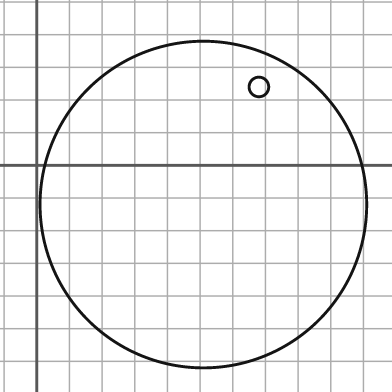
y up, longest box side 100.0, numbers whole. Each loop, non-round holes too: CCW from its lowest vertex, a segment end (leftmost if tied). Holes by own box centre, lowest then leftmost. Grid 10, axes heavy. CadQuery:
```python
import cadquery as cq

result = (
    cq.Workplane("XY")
    .moveTo(51.0, -12.0)
    .circle(50.0)
    .moveTo(68.0, 24.0)
    .circle(3.0)
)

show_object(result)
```